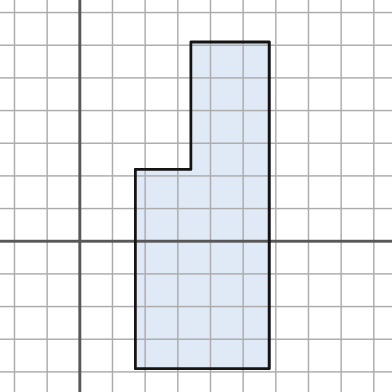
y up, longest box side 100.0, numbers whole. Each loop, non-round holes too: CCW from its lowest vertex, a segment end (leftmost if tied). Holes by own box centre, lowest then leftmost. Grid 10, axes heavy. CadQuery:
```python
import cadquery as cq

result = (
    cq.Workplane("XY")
    .moveTo(17.0, -39.0)
    .lineTo(58.0, -39.0)
    .lineTo(58.0, 61.0)
    .lineTo(34.0, 61.0)
    .lineTo(34.0, 22.0)
    .lineTo(17.0, 22.0)
    .close()
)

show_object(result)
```